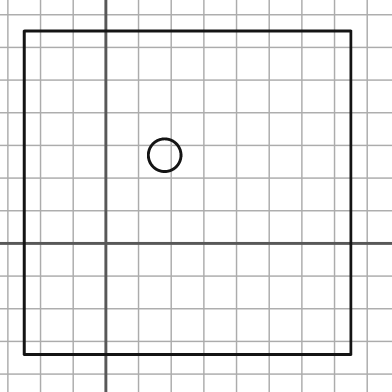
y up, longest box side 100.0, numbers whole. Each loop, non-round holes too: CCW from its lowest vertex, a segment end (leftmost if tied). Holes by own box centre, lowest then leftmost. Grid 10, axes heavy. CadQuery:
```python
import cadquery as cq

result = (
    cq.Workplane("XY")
    .moveTo(-25.0, -34.0)
    .lineTo(75.0, -34.0)
    .lineTo(75.0, 65.0)
    .lineTo(-25.0, 65.0)
    .close()
    .moveTo(18.0, 27.0)
    .circle(5.0)
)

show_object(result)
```